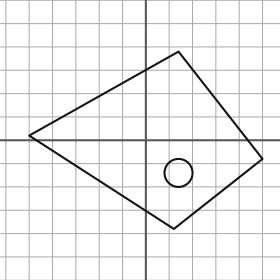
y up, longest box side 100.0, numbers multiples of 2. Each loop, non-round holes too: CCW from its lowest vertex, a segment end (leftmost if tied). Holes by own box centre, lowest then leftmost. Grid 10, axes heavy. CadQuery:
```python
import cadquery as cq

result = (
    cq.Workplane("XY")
    .moveTo(12.0, -38.0)
    .lineTo(50.0, -8.0)
    .lineTo(14.0, 38.0)
    .lineTo(-50.0, 2.0)
    .close()
    .moveTo(14.0, -14.0)
    .circle(6.0)
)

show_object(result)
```